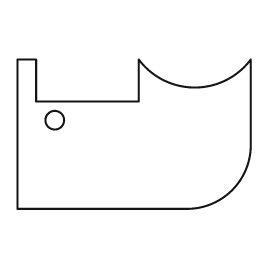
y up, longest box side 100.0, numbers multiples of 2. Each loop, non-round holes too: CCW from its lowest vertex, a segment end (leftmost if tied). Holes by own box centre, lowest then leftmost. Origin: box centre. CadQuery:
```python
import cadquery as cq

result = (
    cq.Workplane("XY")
    .moveTo(-50.0, -32.0)
    .lineTo(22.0, -32.0)
    .threePointArc((42.0, -24.0), (50.0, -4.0))
    .lineTo(50.0, 32.0)
    .threePointArc((26.0, 20.0), (2.0, 32.0))
    .lineTo(2.0, 14.0)
    .lineTo(-42.0, 14.0)
    .lineTo(-42.0, 32.0)
    .lineTo(-50.0, 32.0)
    .close()
    .moveTo(-34.0, 6.0)
    .circle(4.0)
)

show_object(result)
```